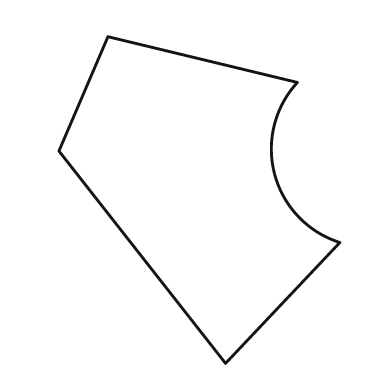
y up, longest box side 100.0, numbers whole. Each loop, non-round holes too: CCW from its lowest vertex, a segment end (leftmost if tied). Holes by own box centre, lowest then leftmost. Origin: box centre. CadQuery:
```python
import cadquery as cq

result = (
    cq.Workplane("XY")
    .moveTo(8.0, -50.0)
    .lineTo(43.0, -13.0)
    .threePointArc((23.0, 8.0), (30.0, 36.0))
    .lineTo(-28.0, 50.0)
    .lineTo(-43.0, 15.0)
    .close()
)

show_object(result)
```